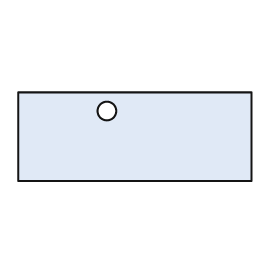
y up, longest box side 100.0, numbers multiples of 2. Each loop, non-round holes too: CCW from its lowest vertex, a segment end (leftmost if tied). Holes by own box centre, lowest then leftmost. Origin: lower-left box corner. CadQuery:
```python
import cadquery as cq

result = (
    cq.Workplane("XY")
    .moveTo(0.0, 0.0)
    .lineTo(100.0, 0.0)
    .lineTo(100.0, 38.0)
    .lineTo(0.0, 38.0)
    .close()
    .moveTo(38.0, 30.0)
    .circle(4.0)
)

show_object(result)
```